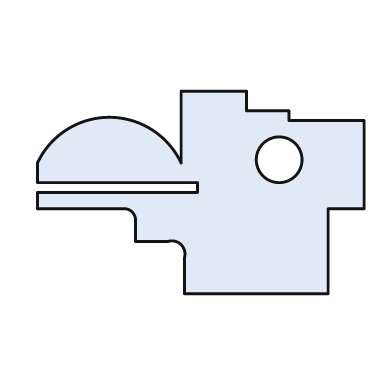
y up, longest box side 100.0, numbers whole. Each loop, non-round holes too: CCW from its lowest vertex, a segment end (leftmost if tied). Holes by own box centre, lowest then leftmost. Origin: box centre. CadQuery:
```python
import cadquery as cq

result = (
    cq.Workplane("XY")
    .moveTo(-5.0, -31.0)
    .lineTo(39.0, -31.0)
    .lineTo(39.0, -5.0)
    .lineTo(50.0, -5.0)
    .lineTo(50.0, 22.0)
    .lineTo(27.0, 22.0)
    .lineTo(27.0, 25.0)
    .lineTo(14.0, 25.0)
    .lineTo(14.0, 31.0)
    .lineTo(-6.0, 31.0)
    .lineTo(-6.0, 9.0)
    .threePointArc((-28.0, 23.0), (-50.0, 9.0))
    .lineTo(-50.0, 3.0)
    .lineTo(-1.0, 3.0)
    .lineTo(-1.0, 0.0)
    .lineTo(-50.0, 0.0)
    .lineTo(-50.0, -5.0)
    .lineTo(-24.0, -5.0)
    .threePointArc((-21.0, -6.0), (-20.0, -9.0))
    .lineTo(-20.0, -15.0)
    .lineTo(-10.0, -15.0)
    .threePointArc((-6.0, -16.0), (-5.0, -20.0))
    .close()
    .moveTo(24.0, 10.0)
    .circle(7.0)
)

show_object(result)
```